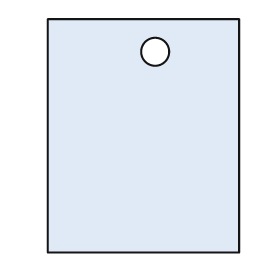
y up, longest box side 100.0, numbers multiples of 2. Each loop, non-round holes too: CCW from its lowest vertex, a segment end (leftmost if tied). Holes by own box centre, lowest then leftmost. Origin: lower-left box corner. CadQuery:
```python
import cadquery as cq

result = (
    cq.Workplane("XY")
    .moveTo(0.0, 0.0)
    .lineTo(82.0, 0.0)
    .lineTo(82.0, 100.0)
    .lineTo(0.0, 100.0)
    .close()
    .moveTo(46.0, 86.0)
    .circle(6.0)
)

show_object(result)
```